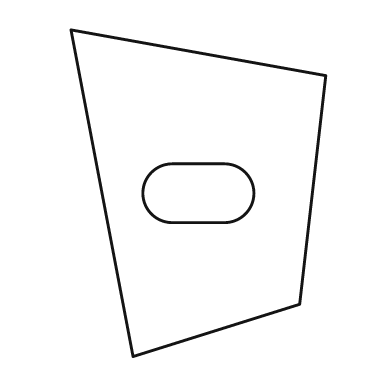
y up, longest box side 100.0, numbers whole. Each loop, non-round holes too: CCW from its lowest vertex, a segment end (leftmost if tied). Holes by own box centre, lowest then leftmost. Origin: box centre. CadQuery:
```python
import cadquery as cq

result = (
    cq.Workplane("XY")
    .moveTo(-20.0, -50.0)
    .lineTo(31.0, -34.0)
    .lineTo(39.0, 36.0)
    .lineTo(-39.0, 50.0)
    .close()
    .moveTo(-8.0, -9.0)
    .lineTo(8.0, -9.0)
    .threePointArc((17.0, 0.0), (8.0, 9.0))
    .lineTo(-8.0, 9.0)
    .threePointArc((-17.0, 0.0), (-8.0, -9.0))
    .close()
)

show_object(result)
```